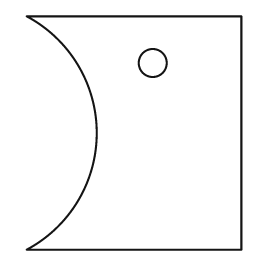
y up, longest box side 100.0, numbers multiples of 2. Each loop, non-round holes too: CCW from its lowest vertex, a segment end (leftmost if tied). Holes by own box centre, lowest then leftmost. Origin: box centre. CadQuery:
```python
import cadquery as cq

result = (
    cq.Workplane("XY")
    .moveTo(-46.0, -50.0)
    .lineTo(46.0, -50.0)
    .lineTo(46.0, 50.0)
    .lineTo(-46.0, 50.0)
    .threePointArc((-16.0, 0.0), (-46.0, -50.0))
    .close()
    .moveTo(8.0, 30.0)
    .circle(6.0)
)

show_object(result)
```